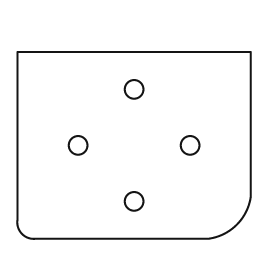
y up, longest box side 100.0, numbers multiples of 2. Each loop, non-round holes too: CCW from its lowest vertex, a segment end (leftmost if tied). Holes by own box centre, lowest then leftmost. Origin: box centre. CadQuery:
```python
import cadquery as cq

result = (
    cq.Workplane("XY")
    .moveTo(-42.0, -40.0)
    .lineTo(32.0, -40.0)
    .threePointArc((44.0, -34.0), (50.0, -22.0))
    .lineTo(50.0, 40.0)
    .lineTo(-50.0, 40.0)
    .lineTo(-50.0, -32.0)
    .threePointArc((-48.0, -38.0), (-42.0, -40.0))
    .close()
    .moveTo(0.0, -24.0)
    .circle(4.0)
    .moveTo(-24.0, 0.0)
    .circle(4.0)
    .moveTo(24.0, 0.0)
    .circle(4.0)
    .moveTo(0.0, 24.0)
    .circle(4.0)
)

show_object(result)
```